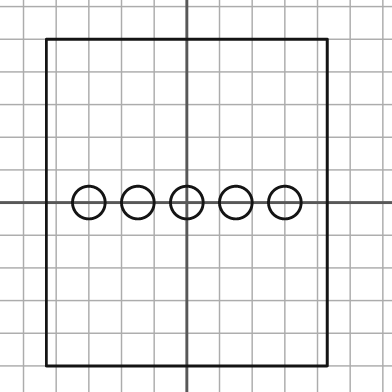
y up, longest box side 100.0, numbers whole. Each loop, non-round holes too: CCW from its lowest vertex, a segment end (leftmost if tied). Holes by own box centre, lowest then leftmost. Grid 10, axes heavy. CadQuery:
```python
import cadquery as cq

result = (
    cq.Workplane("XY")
    .moveTo(-43.0, -50.0)
    .lineTo(43.0, -50.0)
    .lineTo(43.0, 50.0)
    .lineTo(-43.0, 50.0)
    .close()
    .moveTo(-30.0, 0.0)
    .circle(5.0)
    .moveTo(-15.0, 0.0)
    .circle(5.0)
    .moveTo(0.0, 0.0)
    .circle(5.0)
    .moveTo(15.0, 0.0)
    .circle(5.0)
    .moveTo(30.0, 0.0)
    .circle(5.0)
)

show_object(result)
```